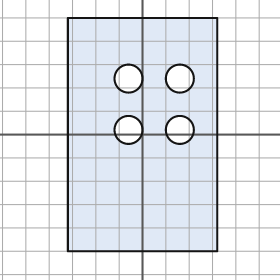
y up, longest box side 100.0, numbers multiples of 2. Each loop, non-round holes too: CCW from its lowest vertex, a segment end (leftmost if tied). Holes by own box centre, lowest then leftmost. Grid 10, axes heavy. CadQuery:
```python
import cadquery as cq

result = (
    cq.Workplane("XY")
    .moveTo(-32.0, -50.0)
    .lineTo(32.0, -50.0)
    .lineTo(32.0, 50.0)
    .lineTo(-32.0, 50.0)
    .close()
    .moveTo(-6.0, 2.0)
    .circle(6.0)
    .moveTo(16.0, 2.0)
    .circle(6.0)
    .moveTo(-6.0, 24.0)
    .circle(6.0)
    .moveTo(16.0, 24.0)
    .circle(6.0)
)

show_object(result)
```